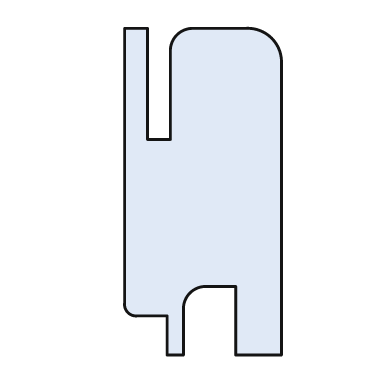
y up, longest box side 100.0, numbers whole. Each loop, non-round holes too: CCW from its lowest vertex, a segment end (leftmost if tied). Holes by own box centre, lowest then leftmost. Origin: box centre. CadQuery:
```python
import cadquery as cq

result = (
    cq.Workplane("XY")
    .moveTo(-11.0, -50.0)
    .lineTo(-6.0, -50.0)
    .lineTo(-6.0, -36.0)
    .threePointArc((-4.0, -31.0), (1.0, -29.0))
    .lineTo(10.0, -29.0)
    .lineTo(10.0, -50.0)
    .lineTo(24.0, -50.0)
    .lineTo(24.0, 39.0)
    .threePointArc((21.0, 47.0), (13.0, 50.0))
    .lineTo(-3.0, 50.0)
    .threePointArc((-8.0, 48.0), (-10.0, 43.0))
    .lineTo(-10.0, 16.0)
    .lineTo(-17.0, 16.0)
    .lineTo(-17.0, 50.0)
    .lineTo(-24.0, 50.0)
    .lineTo(-24.0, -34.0)
    .threePointArc((-23.0, -37.0), (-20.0, -38.0))
    .lineTo(-11.0, -38.0)
    .close()
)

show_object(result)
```